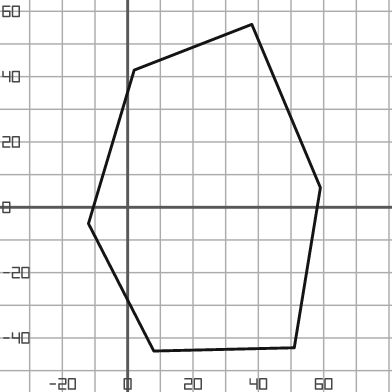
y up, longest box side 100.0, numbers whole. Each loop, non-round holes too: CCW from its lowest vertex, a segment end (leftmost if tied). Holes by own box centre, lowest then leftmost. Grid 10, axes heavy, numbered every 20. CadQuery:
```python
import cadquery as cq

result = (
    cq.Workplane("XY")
    .moveTo(8.0, -44.0)
    .lineTo(51.0, -43.0)
    .lineTo(59.0, 6.0)
    .lineTo(38.0, 56.0)
    .lineTo(2.0, 42.0)
    .lineTo(-12.0, -5.0)
    .close()
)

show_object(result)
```